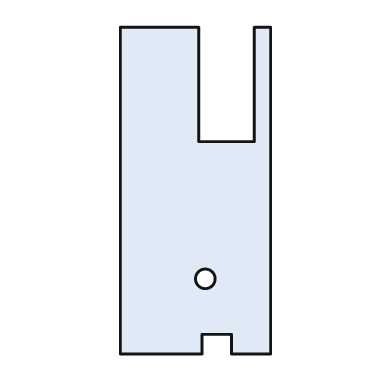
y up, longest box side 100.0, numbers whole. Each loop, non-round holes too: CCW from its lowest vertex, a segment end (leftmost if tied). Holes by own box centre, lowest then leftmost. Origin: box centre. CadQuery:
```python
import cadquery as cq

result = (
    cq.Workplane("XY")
    .moveTo(-23.0, -50.0)
    .lineTo(2.0, -50.0)
    .lineTo(2.0, -44.0)
    .lineTo(11.0, -44.0)
    .lineTo(11.0, -50.0)
    .lineTo(23.0, -50.0)
    .lineTo(23.0, 50.0)
    .lineTo(18.0, 50.0)
    .lineTo(18.0, 15.0)
    .lineTo(1.0, 15.0)
    .lineTo(1.0, 50.0)
    .lineTo(-23.0, 50.0)
    .close()
    .moveTo(3.0, -27.0)
    .circle(3.0)
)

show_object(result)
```